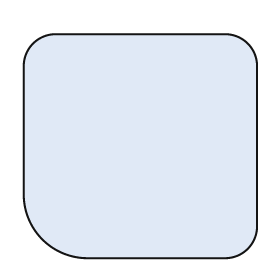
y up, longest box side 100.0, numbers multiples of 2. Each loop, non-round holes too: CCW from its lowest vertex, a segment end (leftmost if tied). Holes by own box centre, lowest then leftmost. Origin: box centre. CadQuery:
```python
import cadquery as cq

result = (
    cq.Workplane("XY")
    .moveTo(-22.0, -48.0)
    .lineTo(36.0, -48.0)
    .threePointArc((46.0, -44.0), (50.0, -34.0))
    .lineTo(50.0, 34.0)
    .threePointArc((46.0, 44.0), (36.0, 48.0))
    .lineTo(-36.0, 48.0)
    .threePointArc((-46.0, 44.0), (-50.0, 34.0))
    .lineTo(-50.0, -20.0)
    .threePointArc((-42.0, -40.0), (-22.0, -48.0))
    .close()
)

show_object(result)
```